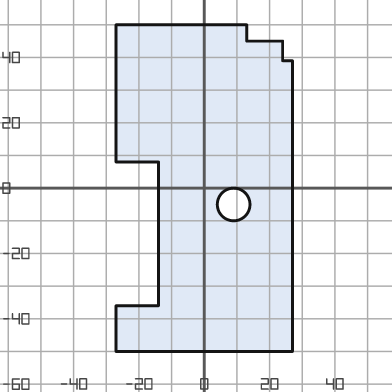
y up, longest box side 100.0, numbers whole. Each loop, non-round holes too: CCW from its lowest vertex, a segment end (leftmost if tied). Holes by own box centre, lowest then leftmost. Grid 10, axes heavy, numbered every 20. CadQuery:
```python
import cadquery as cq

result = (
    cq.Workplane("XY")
    .moveTo(-27.0, -50.0)
    .lineTo(27.0, -50.0)
    .lineTo(27.0, 39.0)
    .lineTo(24.0, 39.0)
    .lineTo(24.0, 45.0)
    .lineTo(13.0, 45.0)
    .lineTo(13.0, 50.0)
    .lineTo(-27.0, 50.0)
    .lineTo(-27.0, 8.0)
    .lineTo(-14.0, 8.0)
    .lineTo(-14.0, -36.0)
    .lineTo(-27.0, -36.0)
    .close()
    .moveTo(9.0, -5.0)
    .circle(5.0)
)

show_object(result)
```